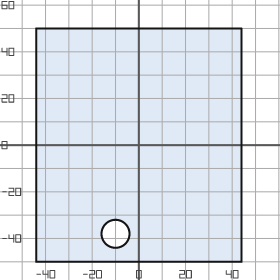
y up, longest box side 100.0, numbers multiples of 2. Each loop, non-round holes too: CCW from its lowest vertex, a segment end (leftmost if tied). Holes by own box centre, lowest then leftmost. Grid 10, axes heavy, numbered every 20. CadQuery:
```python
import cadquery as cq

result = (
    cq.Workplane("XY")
    .moveTo(-44.0, -50.0)
    .lineTo(44.0, -50.0)
    .lineTo(44.0, 50.0)
    .lineTo(-44.0, 50.0)
    .close()
    .moveTo(-10.0, -38.0)
    .circle(6.0)
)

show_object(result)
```